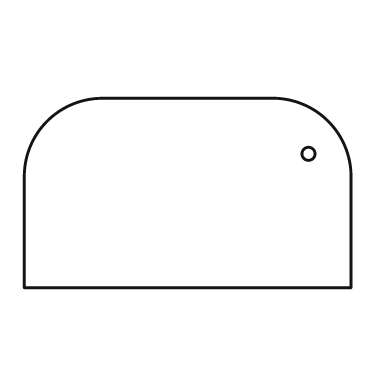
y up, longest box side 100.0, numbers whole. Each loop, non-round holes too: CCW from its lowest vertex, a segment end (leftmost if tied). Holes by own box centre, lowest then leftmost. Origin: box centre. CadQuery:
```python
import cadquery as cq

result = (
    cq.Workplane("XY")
    .moveTo(-50.0, -29.0)
    .lineTo(50.0, -29.0)
    .lineTo(50.0, 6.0)
    .threePointArc((43.0, 22.0), (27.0, 29.0))
    .lineTo(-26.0, 29.0)
    .threePointArc((-43.0, 22.0), (-50.0, 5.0))
    .close()
    .moveTo(37.0, 12.0)
    .circle(2.0)
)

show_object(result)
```